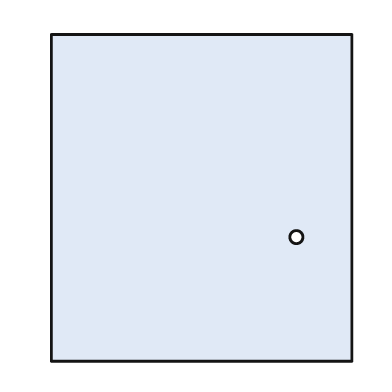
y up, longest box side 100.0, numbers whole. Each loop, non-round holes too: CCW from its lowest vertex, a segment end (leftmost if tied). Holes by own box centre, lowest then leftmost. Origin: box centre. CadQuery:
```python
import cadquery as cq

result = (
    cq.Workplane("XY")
    .moveTo(-46.0, -50.0)
    .lineTo(46.0, -50.0)
    .lineTo(46.0, 50.0)
    .lineTo(-46.0, 50.0)
    .close()
    .moveTo(29.0, -12.0)
    .circle(2.0)
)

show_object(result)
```